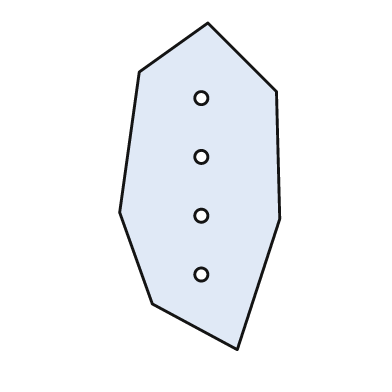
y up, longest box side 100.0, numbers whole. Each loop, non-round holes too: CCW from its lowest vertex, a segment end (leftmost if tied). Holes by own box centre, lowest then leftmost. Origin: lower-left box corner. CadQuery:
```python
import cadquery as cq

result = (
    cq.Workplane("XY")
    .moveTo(36.0, 0.0)
    .lineTo(49.0, 40.0)
    .lineTo(48.0, 79.0)
    .lineTo(27.0, 100.0)
    .lineTo(6.0, 85.0)
    .lineTo(0.0, 42.0)
    .lineTo(10.0, 14.0)
    .close()
    .moveTo(25.0, 23.0)
    .circle(2.0)
    .moveTo(25.0, 41.0)
    .circle(2.0)
    .moveTo(25.0, 59.0)
    .circle(2.0)
    .moveTo(25.0, 77.0)
    .circle(2.0)
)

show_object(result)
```